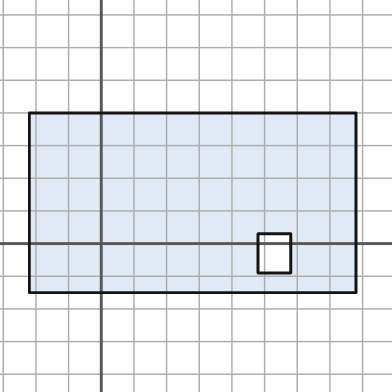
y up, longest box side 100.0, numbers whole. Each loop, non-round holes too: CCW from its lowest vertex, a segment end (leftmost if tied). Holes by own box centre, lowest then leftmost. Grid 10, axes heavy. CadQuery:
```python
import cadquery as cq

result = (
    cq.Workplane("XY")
    .moveTo(-22.0, -15.0)
    .lineTo(78.0, -15.0)
    .lineTo(78.0, 40.0)
    .lineTo(-22.0, 40.0)
    .close()
    .moveTo(48.0, -9.0)
    .lineTo(58.0, -9.0)
    .lineTo(58.0, 3.0)
    .lineTo(48.0, 3.0)
    .close()
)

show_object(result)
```